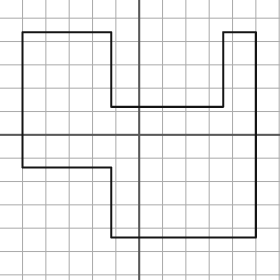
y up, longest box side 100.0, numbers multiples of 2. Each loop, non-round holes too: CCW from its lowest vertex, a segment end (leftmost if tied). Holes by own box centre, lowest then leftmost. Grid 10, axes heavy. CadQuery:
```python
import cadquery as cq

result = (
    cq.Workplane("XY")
    .moveTo(-12.0, -44.0)
    .lineTo(50.0, -44.0)
    .lineTo(50.0, 44.0)
    .lineTo(36.0, 44.0)
    .lineTo(36.0, 12.0)
    .lineTo(-12.0, 12.0)
    .lineTo(-12.0, 44.0)
    .lineTo(-50.0, 44.0)
    .lineTo(-50.0, -14.0)
    .lineTo(-12.0, -14.0)
    .close()
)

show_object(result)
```